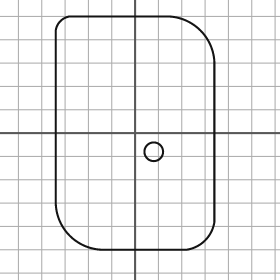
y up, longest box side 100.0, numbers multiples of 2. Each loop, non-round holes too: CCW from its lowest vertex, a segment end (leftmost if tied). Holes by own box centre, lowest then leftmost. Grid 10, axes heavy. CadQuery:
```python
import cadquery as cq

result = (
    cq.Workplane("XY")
    .moveTo(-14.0, -50.0)
    .lineTo(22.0, -50.0)
    .threePointArc((30.0, -46.0), (34.0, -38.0))
    .lineTo(34.0, 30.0)
    .threePointArc((28.0, 44.0), (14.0, 50.0))
    .lineTo(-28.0, 50.0)
    .threePointArc((-32.0, 48.0), (-34.0, 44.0))
    .lineTo(-34.0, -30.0)
    .threePointArc((-28.0, -44.0), (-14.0, -50.0))
    .close()
    .moveTo(8.0, -8.0)
    .circle(4.0)
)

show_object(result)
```